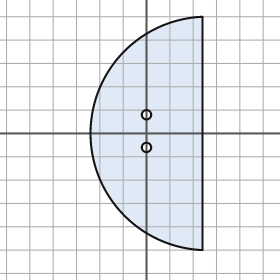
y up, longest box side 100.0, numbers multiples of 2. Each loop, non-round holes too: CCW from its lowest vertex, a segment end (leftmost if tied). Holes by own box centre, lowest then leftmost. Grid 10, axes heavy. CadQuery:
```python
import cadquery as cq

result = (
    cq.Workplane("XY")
    .moveTo(24.0, -50.0)
    .lineTo(24.0, 50.0)
    .threePointArc((-24.0, 0.0), (24.0, -50.0))
    .close()
    .moveTo(0.0, -6.0)
    .circle(2.0)
    .moveTo(0.0, 8.0)
    .circle(2.0)
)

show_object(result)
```